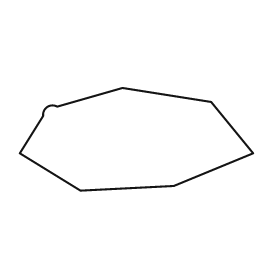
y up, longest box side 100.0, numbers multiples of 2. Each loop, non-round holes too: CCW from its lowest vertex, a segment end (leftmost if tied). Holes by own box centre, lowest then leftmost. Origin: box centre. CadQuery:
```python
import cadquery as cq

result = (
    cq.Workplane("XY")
    .moveTo(-24.0, -22.0)
    .lineTo(16.0, -20.0)
    .lineTo(50.0, -6.0)
    .lineTo(32.0, 16.0)
    .lineTo(-6.0, 22.0)
    .lineTo(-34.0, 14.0)
    .threePointArc((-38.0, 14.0), (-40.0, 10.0))
    .lineTo(-50.0, -6.0)
    .close()
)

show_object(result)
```